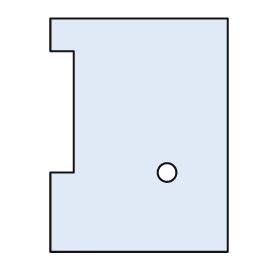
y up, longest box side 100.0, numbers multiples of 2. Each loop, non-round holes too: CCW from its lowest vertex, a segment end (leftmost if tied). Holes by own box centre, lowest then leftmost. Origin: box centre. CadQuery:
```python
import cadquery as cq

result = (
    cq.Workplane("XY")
    .moveTo(-38.0, -50.0)
    .lineTo(38.0, -50.0)
    .lineTo(38.0, 50.0)
    .lineTo(-38.0, 50.0)
    .lineTo(-38.0, 36.0)
    .lineTo(-28.0, 36.0)
    .lineTo(-28.0, -16.0)
    .lineTo(-38.0, -16.0)
    .close()
    .moveTo(12.0, -16.0)
    .circle(4.0)
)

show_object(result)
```